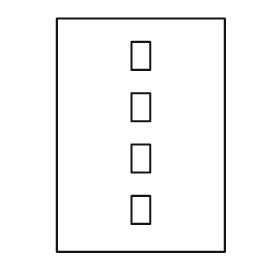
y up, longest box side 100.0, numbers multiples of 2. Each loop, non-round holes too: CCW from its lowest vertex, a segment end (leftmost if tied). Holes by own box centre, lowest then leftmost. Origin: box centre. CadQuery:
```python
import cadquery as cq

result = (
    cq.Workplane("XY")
    .moveTo(-36.0, -50.0)
    .lineTo(36.0, -50.0)
    .lineTo(36.0, 50.0)
    .lineTo(-36.0, 50.0)
    .close()
    .moveTo(-4.0, -38.0)
    .lineTo(4.0, -38.0)
    .lineTo(4.0, -26.0)
    .lineTo(-4.0, -26.0)
    .close()
    .moveTo(-4.0, -16.0)
    .lineTo(4.0, -16.0)
    .lineTo(4.0, -4.0)
    .lineTo(-4.0, -4.0)
    .close()
    .moveTo(-4.0, 6.0)
    .lineTo(4.0, 6.0)
    .lineTo(4.0, 18.0)
    .lineTo(-4.0, 18.0)
    .close()
    .moveTo(-4.0, 28.0)
    .lineTo(4.0, 28.0)
    .lineTo(4.0, 40.0)
    .lineTo(-4.0, 40.0)
    .close()
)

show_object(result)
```